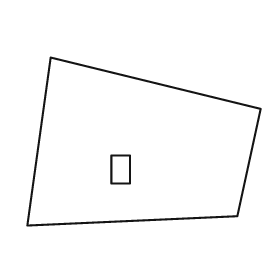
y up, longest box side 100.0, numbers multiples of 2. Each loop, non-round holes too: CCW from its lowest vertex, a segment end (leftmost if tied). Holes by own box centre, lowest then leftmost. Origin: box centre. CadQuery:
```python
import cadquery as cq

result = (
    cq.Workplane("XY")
    .moveTo(-50.0, -36.0)
    .lineTo(40.0, -32.0)
    .lineTo(50.0, 14.0)
    .lineTo(-40.0, 36.0)
    .close()
    .moveTo(-14.0, -18.0)
    .lineTo(-6.0, -18.0)
    .lineTo(-6.0, -6.0)
    .lineTo(-14.0, -6.0)
    .close()
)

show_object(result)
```